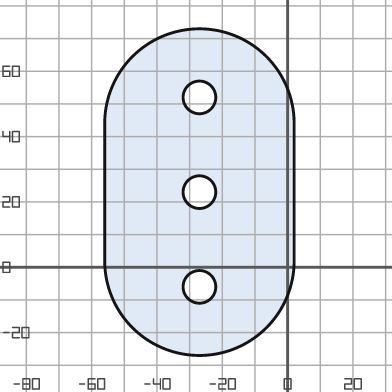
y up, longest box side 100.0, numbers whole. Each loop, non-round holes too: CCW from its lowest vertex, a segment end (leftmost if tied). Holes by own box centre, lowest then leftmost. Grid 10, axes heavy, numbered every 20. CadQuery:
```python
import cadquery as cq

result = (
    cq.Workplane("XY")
    .moveTo(-56.0, 2.0)
    .threePointArc((-27.0, -27.0), (2.0, 2.0))
    .lineTo(2.0, 44.0)
    .threePointArc((-27.0, 73.0), (-56.0, 44.0))
    .close()
    .moveTo(-27.0, -6.0)
    .circle(5.0)
    .moveTo(-27.0, 23.0)
    .circle(5.0)
    .moveTo(-27.0, 52.0)
    .circle(5.0)
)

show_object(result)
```